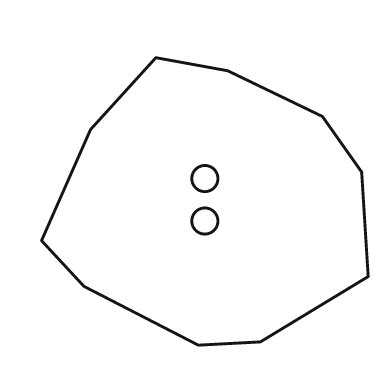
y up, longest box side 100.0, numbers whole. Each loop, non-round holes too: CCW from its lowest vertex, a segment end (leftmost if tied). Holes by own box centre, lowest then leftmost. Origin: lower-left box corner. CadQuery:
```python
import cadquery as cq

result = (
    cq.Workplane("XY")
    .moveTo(48.0, 0.0)
    .lineTo(67.0, 1.0)
    .lineTo(100.0, 21.0)
    .lineTo(98.0, 53.0)
    .lineTo(86.0, 70.0)
    .lineTo(57.0, 84.0)
    .lineTo(35.0, 88.0)
    .lineTo(15.0, 66.0)
    .lineTo(0.0, 32.0)
    .lineTo(13.0, 18.0)
    .close()
    .moveTo(50.0, 38.0)
    .circle(4.0)
    .moveTo(50.0, 51.0)
    .circle(4.0)
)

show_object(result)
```